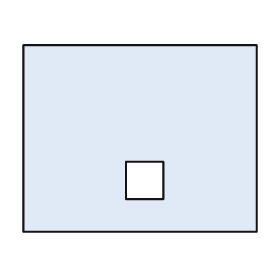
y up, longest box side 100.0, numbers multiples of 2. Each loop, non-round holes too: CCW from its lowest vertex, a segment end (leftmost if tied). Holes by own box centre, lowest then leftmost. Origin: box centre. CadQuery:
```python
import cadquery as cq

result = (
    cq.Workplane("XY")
    .moveTo(-50.0, -40.0)
    .lineTo(50.0, -40.0)
    .lineTo(50.0, 40.0)
    .lineTo(-50.0, 40.0)
    .close()
    .moveTo(-6.0, -26.0)
    .lineTo(10.0, -26.0)
    .lineTo(10.0, -10.0)
    .lineTo(-6.0, -10.0)
    .close()
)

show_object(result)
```